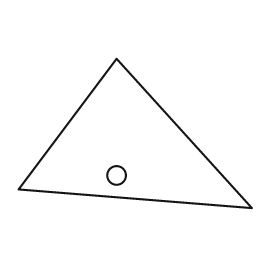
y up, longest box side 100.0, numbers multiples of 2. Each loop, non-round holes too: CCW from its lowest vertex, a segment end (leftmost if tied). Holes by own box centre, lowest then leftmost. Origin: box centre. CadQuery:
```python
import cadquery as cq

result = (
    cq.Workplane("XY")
    .moveTo(50.0, -32.0)
    .lineTo(-8.0, 32.0)
    .lineTo(-50.0, -24.0)
    .close()
    .moveTo(-8.0, -18.0)
    .circle(4.0)
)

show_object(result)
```